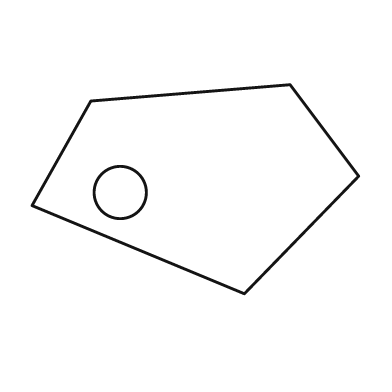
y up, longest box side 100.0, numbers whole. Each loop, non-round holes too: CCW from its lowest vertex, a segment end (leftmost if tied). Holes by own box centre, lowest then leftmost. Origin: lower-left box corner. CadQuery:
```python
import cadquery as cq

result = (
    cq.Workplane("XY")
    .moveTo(65.0, 0.0)
    .lineTo(100.0, 36.0)
    .lineTo(79.0, 64.0)
    .lineTo(18.0, 59.0)
    .lineTo(0.0, 27.0)
    .close()
    .moveTo(27.0, 31.0)
    .circle(8.0)
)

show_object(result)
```